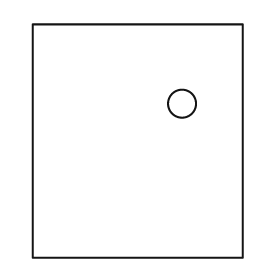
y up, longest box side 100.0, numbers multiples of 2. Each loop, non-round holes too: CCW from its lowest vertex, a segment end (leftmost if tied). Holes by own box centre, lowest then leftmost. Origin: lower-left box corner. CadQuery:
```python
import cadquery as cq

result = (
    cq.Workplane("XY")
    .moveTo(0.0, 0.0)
    .lineTo(90.0, 0.0)
    .lineTo(90.0, 100.0)
    .lineTo(0.0, 100.0)
    .close()
    .moveTo(64.0, 66.0)
    .circle(6.0)
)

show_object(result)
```